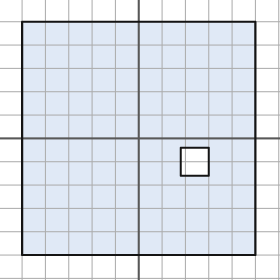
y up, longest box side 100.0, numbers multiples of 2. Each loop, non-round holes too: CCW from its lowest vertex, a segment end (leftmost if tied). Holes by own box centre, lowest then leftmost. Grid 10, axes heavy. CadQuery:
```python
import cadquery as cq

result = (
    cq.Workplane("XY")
    .moveTo(-50.0, -50.0)
    .lineTo(50.0, -50.0)
    .lineTo(50.0, 50.0)
    .lineTo(-50.0, 50.0)
    .close()
    .moveTo(18.0, -16.0)
    .lineTo(30.0, -16.0)
    .lineTo(30.0, -4.0)
    .lineTo(18.0, -4.0)
    .close()
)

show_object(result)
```